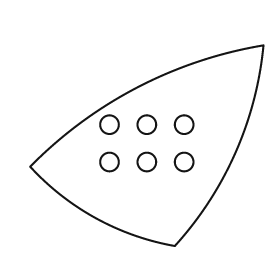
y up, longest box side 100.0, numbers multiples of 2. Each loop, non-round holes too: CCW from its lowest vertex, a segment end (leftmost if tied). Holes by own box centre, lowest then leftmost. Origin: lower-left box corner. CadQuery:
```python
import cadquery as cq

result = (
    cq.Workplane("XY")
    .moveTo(62.0, 0.0)
    .threePointArc((88.0, 40.0), (100.0, 86.0))
    .threePointArc((46.0, 68.0), (0.0, 34.0))
    .threePointArc((28.0, 12.0), (62.0, 0.0))
    .close()
    .moveTo(34.0, 36.0)
    .circle(4.0)
    .moveTo(50.0, 36.0)
    .circle(4.0)
    .moveTo(66.0, 36.0)
    .circle(4.0)
    .moveTo(34.0, 52.0)
    .circle(4.0)
    .moveTo(50.0, 52.0)
    .circle(4.0)
    .moveTo(66.0, 52.0)
    .circle(4.0)
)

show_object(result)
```